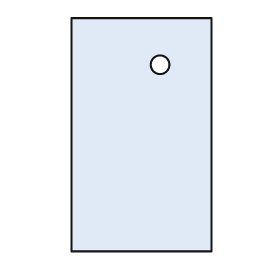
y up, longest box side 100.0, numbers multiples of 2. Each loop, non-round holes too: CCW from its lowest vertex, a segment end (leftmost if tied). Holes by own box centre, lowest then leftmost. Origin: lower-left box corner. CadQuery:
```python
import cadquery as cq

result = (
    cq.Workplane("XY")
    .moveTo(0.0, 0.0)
    .lineTo(60.0, 0.0)
    .lineTo(60.0, 100.0)
    .lineTo(0.0, 100.0)
    .close()
    .moveTo(38.0, 80.0)
    .circle(4.0)
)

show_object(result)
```